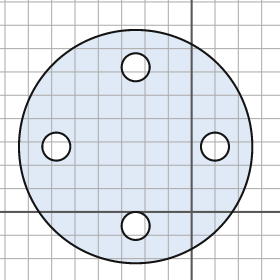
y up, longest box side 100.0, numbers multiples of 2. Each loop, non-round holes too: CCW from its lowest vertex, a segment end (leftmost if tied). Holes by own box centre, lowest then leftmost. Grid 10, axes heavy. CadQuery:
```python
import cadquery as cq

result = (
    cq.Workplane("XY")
    .moveTo(-24.0, 28.0)
    .circle(50.0)
    .moveTo(-24.0, -6.0)
    .circle(6.0)
    .moveTo(-58.0, 28.0)
    .circle(6.0)
    .moveTo(10.0, 28.0)
    .circle(6.0)
    .moveTo(-24.0, 62.0)
    .circle(6.0)
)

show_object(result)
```